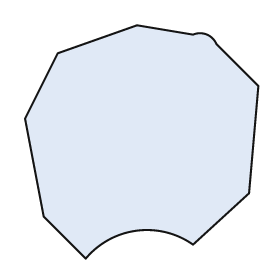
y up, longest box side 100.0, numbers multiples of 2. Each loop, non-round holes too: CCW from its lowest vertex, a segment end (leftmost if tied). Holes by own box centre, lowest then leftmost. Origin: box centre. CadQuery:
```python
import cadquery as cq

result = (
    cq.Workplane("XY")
    .moveTo(-24.0, -50.0)
    .threePointArc((-2.0, -38.0), (22.0, -44.0))
    .lineTo(46.0, -22.0)
    .lineTo(50.0, 24.0)
    .lineTo(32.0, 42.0)
    .threePointArc((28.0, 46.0), (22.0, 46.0))
    .lineTo(-2.0, 50.0)
    .lineTo(-36.0, 38.0)
    .lineTo(-50.0, 10.0)
    .lineTo(-42.0, -32.0)
    .close()
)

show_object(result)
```